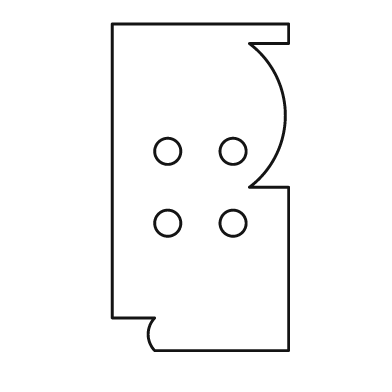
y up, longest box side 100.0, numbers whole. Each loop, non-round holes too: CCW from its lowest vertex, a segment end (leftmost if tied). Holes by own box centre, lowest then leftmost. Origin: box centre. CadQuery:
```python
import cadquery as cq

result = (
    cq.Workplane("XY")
    .moveTo(-14.0, -50.0)
    .lineTo(27.0, -50.0)
    .lineTo(27.0, 0.0)
    .lineTo(15.0, 0.0)
    .threePointArc((26.0, 22.0), (15.0, 44.0))
    .lineTo(27.0, 44.0)
    .lineTo(27.0, 50.0)
    .lineTo(-27.0, 50.0)
    .lineTo(-27.0, -40.0)
    .lineTo(-14.0, -40.0)
    .threePointArc((-16.0, -45.0), (-14.0, -50.0))
    .close()
    .moveTo(-10.0, -11.0)
    .circle(4.0)
    .moveTo(10.0, -11.0)
    .circle(4.0)
    .moveTo(-10.0, 11.0)
    .circle(4.0)
    .moveTo(10.0, 11.0)
    .circle(4.0)
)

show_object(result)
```